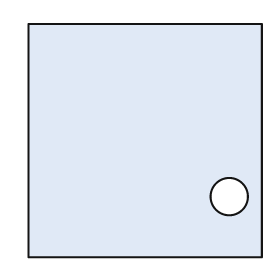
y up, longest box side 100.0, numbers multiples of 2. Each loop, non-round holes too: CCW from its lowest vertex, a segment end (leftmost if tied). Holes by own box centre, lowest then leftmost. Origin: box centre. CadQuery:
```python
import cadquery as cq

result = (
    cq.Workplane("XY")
    .moveTo(-50.0, -50.0)
    .lineTo(50.0, -50.0)
    .lineTo(50.0, 50.0)
    .lineTo(-50.0, 50.0)
    .close()
    .moveTo(36.0, -24.0)
    .circle(8.0)
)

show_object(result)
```